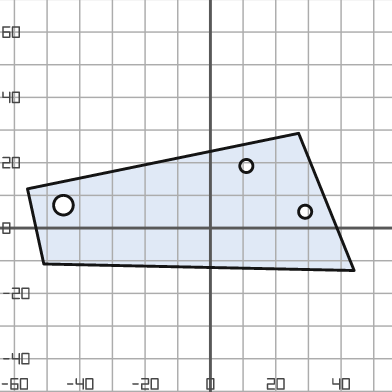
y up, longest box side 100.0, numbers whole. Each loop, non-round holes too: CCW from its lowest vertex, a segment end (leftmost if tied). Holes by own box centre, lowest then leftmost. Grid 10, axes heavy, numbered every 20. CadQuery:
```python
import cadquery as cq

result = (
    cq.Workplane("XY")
    .moveTo(44.0, -13.0)
    .lineTo(27.0, 29.0)
    .lineTo(-56.0, 12.0)
    .lineTo(-51.0, -11.0)
    .close()
    .moveTo(29.0, 5.0)
    .circle(2.0)
    .moveTo(-45.0, 7.0)
    .circle(3.0)
    .moveTo(11.0, 19.0)
    .circle(2.0)
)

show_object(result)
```